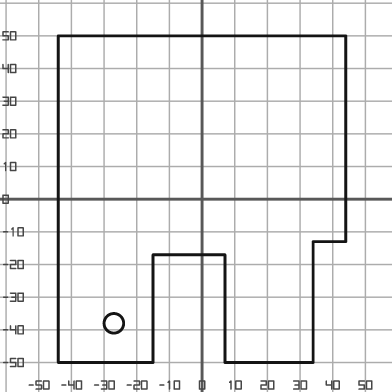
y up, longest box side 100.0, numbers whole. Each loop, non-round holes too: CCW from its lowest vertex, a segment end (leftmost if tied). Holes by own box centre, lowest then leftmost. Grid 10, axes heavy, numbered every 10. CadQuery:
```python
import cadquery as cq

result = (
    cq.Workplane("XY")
    .moveTo(-44.0, -50.0)
    .lineTo(-15.0, -50.0)
    .lineTo(-15.0, -17.0)
    .lineTo(7.0, -17.0)
    .lineTo(7.0, -50.0)
    .lineTo(34.0, -50.0)
    .lineTo(34.0, -13.0)
    .lineTo(44.0, -13.0)
    .lineTo(44.0, 50.0)
    .lineTo(-44.0, 50.0)
    .close()
    .moveTo(-27.0, -38.0)
    .circle(3.0)
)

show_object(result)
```